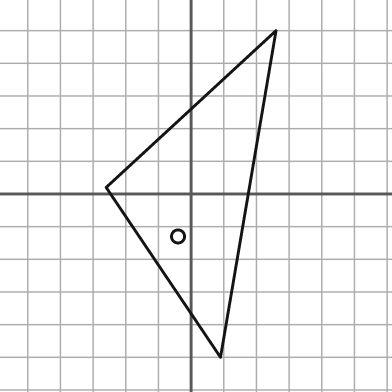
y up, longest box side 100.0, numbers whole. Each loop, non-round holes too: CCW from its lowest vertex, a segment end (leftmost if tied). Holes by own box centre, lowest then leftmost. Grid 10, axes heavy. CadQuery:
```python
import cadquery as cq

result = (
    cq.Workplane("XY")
    .moveTo(9.0, -50.0)
    .lineTo(26.0, 50.0)
    .lineTo(-26.0, 2.0)
    .close()
    .moveTo(-4.0, -13.0)
    .circle(2.0)
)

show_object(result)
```